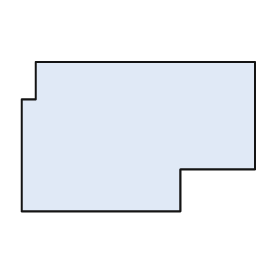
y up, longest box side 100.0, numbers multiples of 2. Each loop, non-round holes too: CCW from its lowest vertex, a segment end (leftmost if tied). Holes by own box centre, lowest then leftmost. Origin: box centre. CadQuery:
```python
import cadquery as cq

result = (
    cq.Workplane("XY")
    .moveTo(-50.0, -32.0)
    .lineTo(18.0, -32.0)
    .lineTo(18.0, -14.0)
    .lineTo(50.0, -14.0)
    .lineTo(50.0, 32.0)
    .lineTo(-44.0, 32.0)
    .lineTo(-44.0, 16.0)
    .lineTo(-50.0, 16.0)
    .close()
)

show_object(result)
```